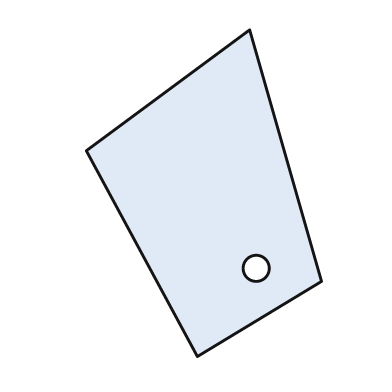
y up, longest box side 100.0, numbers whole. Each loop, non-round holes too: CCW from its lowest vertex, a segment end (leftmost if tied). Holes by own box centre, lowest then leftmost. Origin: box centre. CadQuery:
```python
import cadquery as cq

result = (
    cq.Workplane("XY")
    .moveTo(-2.0, -50.0)
    .lineTo(36.0, -27.0)
    .lineTo(14.0, 50.0)
    .lineTo(-36.0, 13.0)
    .close()
    .moveTo(16.0, -23.0)
    .circle(4.0)
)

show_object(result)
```